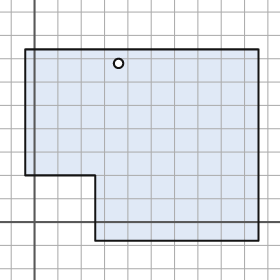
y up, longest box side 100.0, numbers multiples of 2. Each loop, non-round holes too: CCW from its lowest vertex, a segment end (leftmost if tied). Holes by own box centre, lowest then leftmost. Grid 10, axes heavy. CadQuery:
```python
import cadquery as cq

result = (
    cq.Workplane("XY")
    .moveTo(26.0, -8.0)
    .lineTo(96.0, -8.0)
    .lineTo(96.0, 74.0)
    .lineTo(-4.0, 74.0)
    .lineTo(-4.0, 20.0)
    .lineTo(26.0, 20.0)
    .close()
    .moveTo(36.0, 68.0)
    .circle(2.0)
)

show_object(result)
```